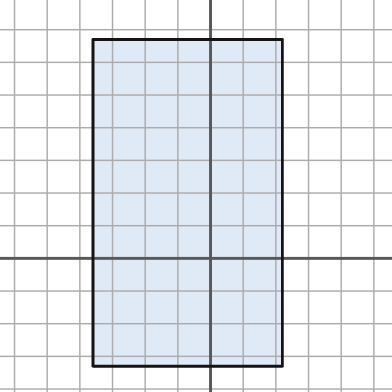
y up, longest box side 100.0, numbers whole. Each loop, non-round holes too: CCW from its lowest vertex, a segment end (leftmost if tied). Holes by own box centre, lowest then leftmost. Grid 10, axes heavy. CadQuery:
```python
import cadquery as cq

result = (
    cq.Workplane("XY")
    .moveTo(-36.0, -33.0)
    .lineTo(22.0, -33.0)
    .lineTo(22.0, 67.0)
    .lineTo(-36.0, 67.0)
    .close()
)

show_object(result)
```